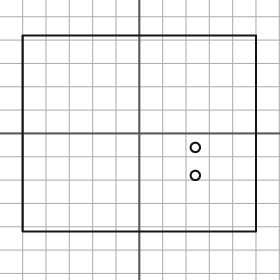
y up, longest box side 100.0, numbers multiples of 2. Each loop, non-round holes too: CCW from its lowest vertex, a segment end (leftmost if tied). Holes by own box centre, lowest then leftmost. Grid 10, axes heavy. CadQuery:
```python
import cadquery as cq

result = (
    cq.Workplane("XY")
    .moveTo(-50.0, -42.0)
    .lineTo(50.0, -42.0)
    .lineTo(50.0, 42.0)
    .lineTo(-50.0, 42.0)
    .close()
    .moveTo(24.0, -18.0)
    .circle(2.0)
    .moveTo(24.0, -6.0)
    .circle(2.0)
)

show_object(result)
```